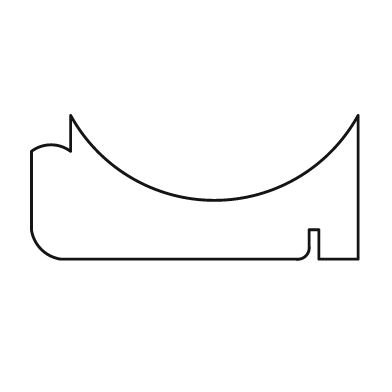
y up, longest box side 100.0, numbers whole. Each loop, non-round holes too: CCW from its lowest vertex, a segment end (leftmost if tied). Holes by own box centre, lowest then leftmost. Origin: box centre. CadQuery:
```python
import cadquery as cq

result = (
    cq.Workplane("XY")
    .moveTo(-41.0, -22.0)
    .lineTo(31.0, -22.0)
    .threePointArc((34.0, -21.0), (35.0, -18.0))
    .lineTo(35.0, -13.0)
    .lineTo(38.0, -13.0)
    .lineTo(38.0, -22.0)
    .lineTo(50.0, -22.0)
    .lineTo(50.0, 22.0)
    .threePointArc((6.0, -4.0), (-38.0, 22.0))
    .lineTo(-38.0, 11.0)
    .threePointArc((-44.0, 13.0), (-50.0, 11.0))
    .lineTo(-50.0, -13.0)
    .threePointArc((-47.0, -19.0), (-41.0, -22.0))
    .close()
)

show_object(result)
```